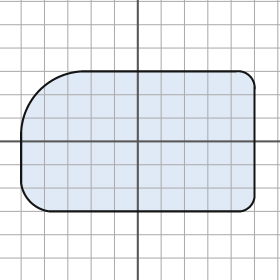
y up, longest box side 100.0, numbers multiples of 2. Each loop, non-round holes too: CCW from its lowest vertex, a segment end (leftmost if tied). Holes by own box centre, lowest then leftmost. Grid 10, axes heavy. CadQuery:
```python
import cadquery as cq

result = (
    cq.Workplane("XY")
    .moveTo(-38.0, -30.0)
    .lineTo(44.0, -30.0)
    .threePointArc((48.0, -28.0), (50.0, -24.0))
    .lineTo(50.0, 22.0)
    .threePointArc((48.0, 28.0), (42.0, 30.0))
    .lineTo(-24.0, 30.0)
    .threePointArc((-42.0, 22.0), (-50.0, 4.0))
    .lineTo(-50.0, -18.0)
    .threePointArc((-46.0, -26.0), (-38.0, -30.0))
    .close()
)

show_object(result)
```